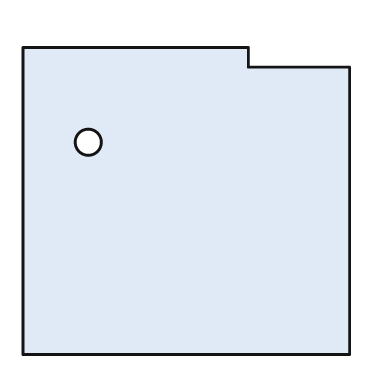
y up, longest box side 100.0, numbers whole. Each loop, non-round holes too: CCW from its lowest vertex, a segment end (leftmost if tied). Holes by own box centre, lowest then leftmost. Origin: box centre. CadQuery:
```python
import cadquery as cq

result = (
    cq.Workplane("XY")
    .moveTo(-50.0, -47.0)
    .lineTo(50.0, -47.0)
    .lineTo(50.0, 41.0)
    .lineTo(19.0, 41.0)
    .lineTo(19.0, 47.0)
    .lineTo(-50.0, 47.0)
    .close()
    .moveTo(-30.0, 18.0)
    .circle(4.0)
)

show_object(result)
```